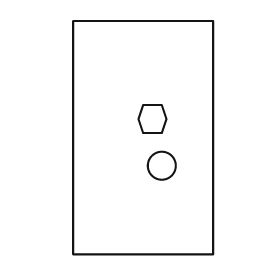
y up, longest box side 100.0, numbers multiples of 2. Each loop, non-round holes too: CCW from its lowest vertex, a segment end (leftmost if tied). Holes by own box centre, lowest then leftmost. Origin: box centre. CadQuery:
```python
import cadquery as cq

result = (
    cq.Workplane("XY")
    .moveTo(-30.0, -50.0)
    .lineTo(30.0, -50.0)
    .lineTo(30.0, 50.0)
    .lineTo(-30.0, 50.0)
    .close()
    .moveTo(8.0, -12.0)
    .circle(6.0)
    .moveTo(0.0, 2.0)
    .lineTo(8.0, 2.0)
    .lineTo(10.0, 8.0)
    .lineTo(8.0, 14.0)
    .lineTo(0.0, 14.0)
    .lineTo(-2.0, 8.0)
    .close()
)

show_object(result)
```